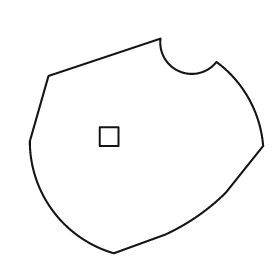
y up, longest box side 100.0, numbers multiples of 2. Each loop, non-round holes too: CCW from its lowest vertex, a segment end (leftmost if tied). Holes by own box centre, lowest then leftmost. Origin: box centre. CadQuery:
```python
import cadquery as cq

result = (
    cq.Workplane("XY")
    .moveTo(-14.0, -46.0)
    .lineTo(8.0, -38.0)
    .threePointArc((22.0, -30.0), (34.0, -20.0))
    .lineTo(50.0, 0.0)
    .threePointArc((44.0, 20.0), (30.0, 36.0))
    .threePointArc((14.0, 32.0), (6.0, 46.0))
    .lineTo(-42.0, 30.0)
    .lineTo(-50.0, 2.0)
    .threePointArc((-40.0, -28.0), (-14.0, -46.0))
    .close()
    .moveTo(-20.0, 0.0)
    .lineTo(-12.0, 0.0)
    .lineTo(-12.0, 8.0)
    .lineTo(-20.0, 8.0)
    .close()
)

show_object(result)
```